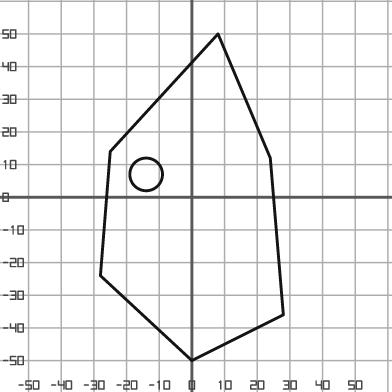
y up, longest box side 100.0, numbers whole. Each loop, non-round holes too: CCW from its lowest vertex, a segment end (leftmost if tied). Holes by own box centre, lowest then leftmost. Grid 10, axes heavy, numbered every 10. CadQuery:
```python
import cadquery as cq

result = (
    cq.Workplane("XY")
    .moveTo(0.0, -50.0)
    .lineTo(28.0, -36.0)
    .lineTo(24.0, 12.0)
    .lineTo(8.0, 50.0)
    .lineTo(-25.0, 14.0)
    .lineTo(-28.0, -24.0)
    .close()
    .moveTo(-14.0, 7.0)
    .circle(5.0)
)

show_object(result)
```